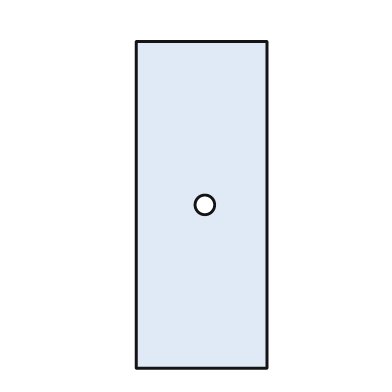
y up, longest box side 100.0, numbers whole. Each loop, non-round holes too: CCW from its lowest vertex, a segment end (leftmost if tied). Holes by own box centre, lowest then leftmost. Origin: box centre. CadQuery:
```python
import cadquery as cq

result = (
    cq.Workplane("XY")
    .moveTo(-20.0, -50.0)
    .lineTo(20.0, -50.0)
    .lineTo(20.0, 50.0)
    .lineTo(-20.0, 50.0)
    .close()
    .moveTo(1.0, 0.0)
    .circle(3.0)
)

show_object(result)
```